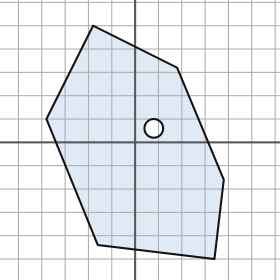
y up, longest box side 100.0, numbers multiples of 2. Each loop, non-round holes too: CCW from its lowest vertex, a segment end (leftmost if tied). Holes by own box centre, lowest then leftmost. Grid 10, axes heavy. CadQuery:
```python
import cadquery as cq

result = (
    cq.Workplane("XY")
    .moveTo(34.0, -50.0)
    .lineTo(38.0, -16.0)
    .lineTo(18.0, 32.0)
    .lineTo(-18.0, 50.0)
    .lineTo(-38.0, 10.0)
    .lineTo(-16.0, -44.0)
    .close()
    .moveTo(8.0, 6.0)
    .circle(4.0)
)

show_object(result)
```